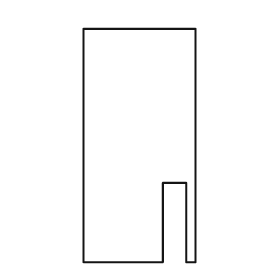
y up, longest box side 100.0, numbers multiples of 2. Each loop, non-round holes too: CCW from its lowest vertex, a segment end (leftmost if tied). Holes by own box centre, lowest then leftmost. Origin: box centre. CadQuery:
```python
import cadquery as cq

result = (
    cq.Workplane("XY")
    .moveTo(-24.0, -50.0)
    .lineTo(10.0, -50.0)
    .lineTo(10.0, -16.0)
    .lineTo(20.0, -16.0)
    .lineTo(20.0, -50.0)
    .lineTo(24.0, -50.0)
    .lineTo(24.0, 50.0)
    .lineTo(-24.0, 50.0)
    .close()
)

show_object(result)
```